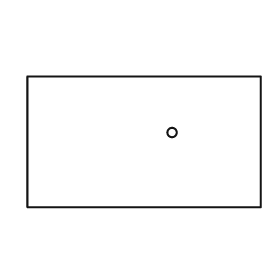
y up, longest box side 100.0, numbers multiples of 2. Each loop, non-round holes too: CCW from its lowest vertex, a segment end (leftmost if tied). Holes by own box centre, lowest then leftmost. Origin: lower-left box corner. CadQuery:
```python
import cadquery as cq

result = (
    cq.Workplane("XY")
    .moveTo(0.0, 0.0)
    .lineTo(100.0, 0.0)
    .lineTo(100.0, 56.0)
    .lineTo(0.0, 56.0)
    .close()
    .moveTo(62.0, 32.0)
    .circle(2.0)
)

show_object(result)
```